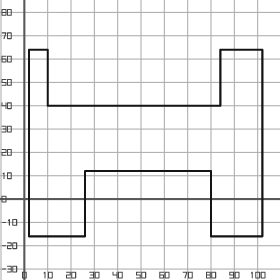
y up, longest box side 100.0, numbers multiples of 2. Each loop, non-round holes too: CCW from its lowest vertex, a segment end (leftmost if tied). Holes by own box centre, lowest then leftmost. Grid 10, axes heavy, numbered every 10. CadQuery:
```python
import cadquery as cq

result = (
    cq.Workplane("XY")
    .moveTo(2.0, -16.0)
    .lineTo(26.0, -16.0)
    .lineTo(26.0, 12.0)
    .lineTo(80.0, 12.0)
    .lineTo(80.0, -16.0)
    .lineTo(102.0, -16.0)
    .lineTo(102.0, 64.0)
    .lineTo(84.0, 64.0)
    .lineTo(84.0, 40.0)
    .lineTo(10.0, 40.0)
    .lineTo(10.0, 64.0)
    .lineTo(2.0, 64.0)
    .close()
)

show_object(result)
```